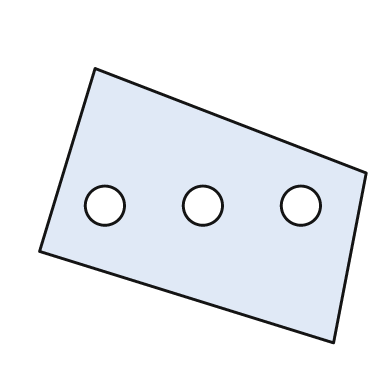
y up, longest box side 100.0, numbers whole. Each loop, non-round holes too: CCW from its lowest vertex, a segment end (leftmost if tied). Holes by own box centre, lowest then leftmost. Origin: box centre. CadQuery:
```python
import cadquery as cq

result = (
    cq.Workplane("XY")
    .moveTo(40.0, -42.0)
    .lineTo(50.0, 10.0)
    .lineTo(-33.0, 42.0)
    .lineTo(-50.0, -14.0)
    .close()
    .moveTo(-30.0, 0.0)
    .circle(6.0)
    .moveTo(0.0, 0.0)
    .circle(6.0)
    .moveTo(30.0, 0.0)
    .circle(6.0)
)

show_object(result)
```